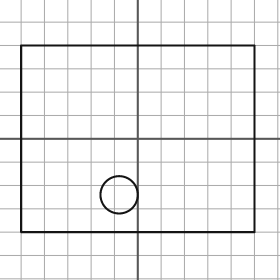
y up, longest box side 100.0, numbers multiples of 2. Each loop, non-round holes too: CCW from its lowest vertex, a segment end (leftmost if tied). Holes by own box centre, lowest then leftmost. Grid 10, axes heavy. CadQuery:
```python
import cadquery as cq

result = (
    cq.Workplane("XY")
    .moveTo(-50.0, -40.0)
    .lineTo(50.0, -40.0)
    .lineTo(50.0, 40.0)
    .lineTo(-50.0, 40.0)
    .close()
    .moveTo(-8.0, -24.0)
    .circle(8.0)
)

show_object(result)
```